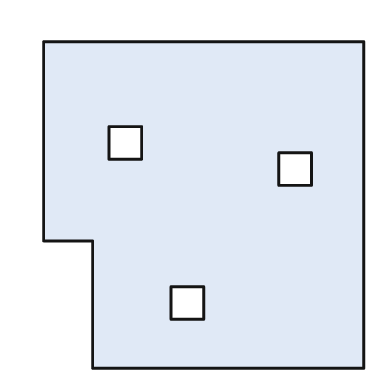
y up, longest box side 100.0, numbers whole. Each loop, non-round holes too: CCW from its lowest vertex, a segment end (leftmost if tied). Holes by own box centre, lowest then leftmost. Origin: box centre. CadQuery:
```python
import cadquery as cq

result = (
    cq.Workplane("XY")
    .moveTo(-34.0, -50.0)
    .lineTo(49.0, -50.0)
    .lineTo(49.0, 50.0)
    .lineTo(-49.0, 50.0)
    .lineTo(-49.0, -11.0)
    .lineTo(-34.0, -11.0)
    .close()
    .moveTo(-10.0, -35.0)
    .lineTo(0.0, -35.0)
    .lineTo(0.0, -25.0)
    .lineTo(-10.0, -25.0)
    .close()
    .moveTo(23.0, 6.0)
    .lineTo(33.0, 6.0)
    .lineTo(33.0, 16.0)
    .lineTo(23.0, 16.0)
    .close()
    .moveTo(-29.0, 14.0)
    .lineTo(-19.0, 14.0)
    .lineTo(-19.0, 24.0)
    .lineTo(-29.0, 24.0)
    .close()
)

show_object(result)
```